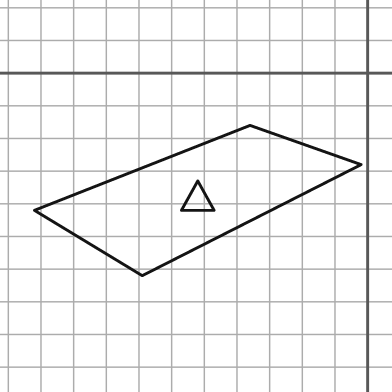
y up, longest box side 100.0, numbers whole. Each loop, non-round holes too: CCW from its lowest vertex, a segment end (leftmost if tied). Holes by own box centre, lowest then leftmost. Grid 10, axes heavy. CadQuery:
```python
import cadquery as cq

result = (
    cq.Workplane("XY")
    .moveTo(-69.0, -62.0)
    .lineTo(-2.0, -28.0)
    .lineTo(-36.0, -16.0)
    .lineTo(-102.0, -42.0)
    .close()
    .moveTo(-57.0, -42.0)
    .lineTo(-47.0, -42.0)
    .lineTo(-52.0, -33.0)
    .close()
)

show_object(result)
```